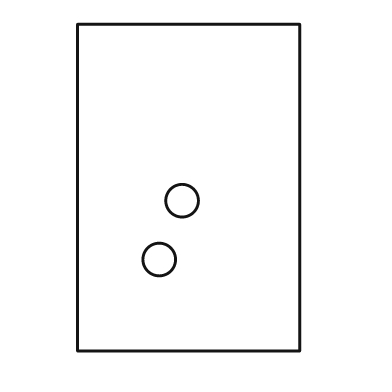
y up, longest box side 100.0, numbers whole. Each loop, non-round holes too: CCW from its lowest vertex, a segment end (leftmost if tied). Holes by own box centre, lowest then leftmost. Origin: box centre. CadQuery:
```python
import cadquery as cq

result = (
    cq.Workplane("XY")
    .moveTo(-34.0, -50.0)
    .lineTo(34.0, -50.0)
    .lineTo(34.0, 50.0)
    .lineTo(-34.0, 50.0)
    .close()
    .moveTo(-9.0, -22.0)
    .circle(5.0)
    .moveTo(-2.0, -4.0)
    .circle(5.0)
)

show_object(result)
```